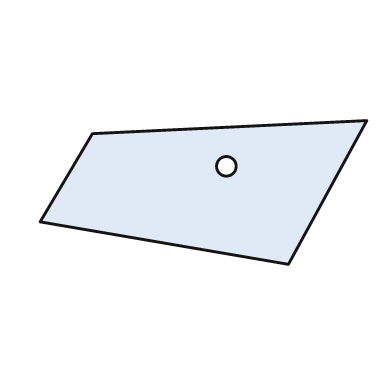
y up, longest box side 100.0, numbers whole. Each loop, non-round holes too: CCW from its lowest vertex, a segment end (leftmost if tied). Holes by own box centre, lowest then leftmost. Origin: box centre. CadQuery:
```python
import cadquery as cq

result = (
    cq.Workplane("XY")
    .moveTo(26.0, -22.0)
    .lineTo(50.0, 22.0)
    .lineTo(-34.0, 18.0)
    .lineTo(-50.0, -9.0)
    .close()
    .moveTo(7.0, 8.0)
    .circle(3.0)
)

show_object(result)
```